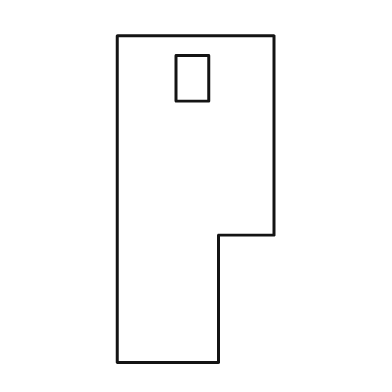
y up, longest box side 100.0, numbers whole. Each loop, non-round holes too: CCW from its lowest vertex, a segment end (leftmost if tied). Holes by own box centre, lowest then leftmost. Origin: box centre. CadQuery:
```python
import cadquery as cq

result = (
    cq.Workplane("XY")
    .moveTo(-24.0, -50.0)
    .lineTo(7.0, -50.0)
    .lineTo(7.0, -11.0)
    .lineTo(24.0, -11.0)
    .lineTo(24.0, 50.0)
    .lineTo(-24.0, 50.0)
    .close()
    .moveTo(-6.0, 30.0)
    .lineTo(4.0, 30.0)
    .lineTo(4.0, 44.0)
    .lineTo(-6.0, 44.0)
    .close()
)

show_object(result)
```